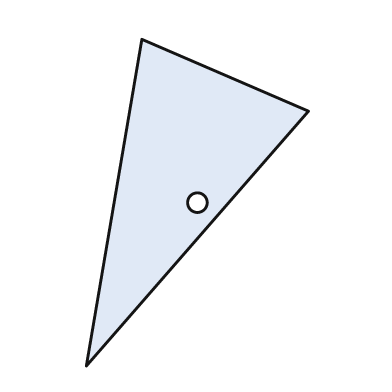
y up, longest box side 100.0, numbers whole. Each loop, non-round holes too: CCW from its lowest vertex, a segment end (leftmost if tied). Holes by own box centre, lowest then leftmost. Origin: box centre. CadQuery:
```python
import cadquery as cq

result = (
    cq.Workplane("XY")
    .moveTo(-34.0, -50.0)
    .lineTo(34.0, 28.0)
    .lineTo(-17.0, 50.0)
    .close()
    .moveTo(0.0, 0.0)
    .circle(3.0)
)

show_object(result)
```